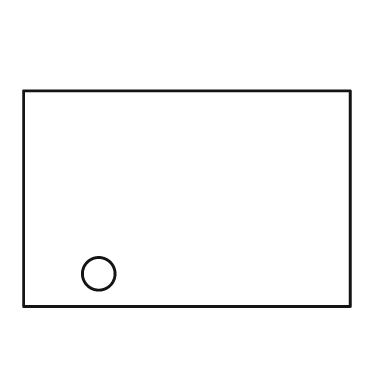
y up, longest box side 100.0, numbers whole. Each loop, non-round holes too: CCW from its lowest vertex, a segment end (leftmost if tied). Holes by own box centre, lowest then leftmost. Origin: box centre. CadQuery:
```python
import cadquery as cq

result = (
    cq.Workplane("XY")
    .moveTo(-50.0, -33.0)
    .lineTo(50.0, -33.0)
    .lineTo(50.0, 33.0)
    .lineTo(-50.0, 33.0)
    .close()
    .moveTo(-27.0, -23.0)
    .circle(5.0)
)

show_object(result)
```